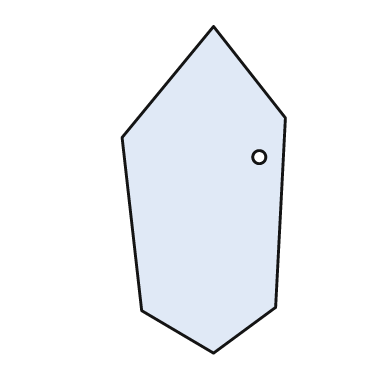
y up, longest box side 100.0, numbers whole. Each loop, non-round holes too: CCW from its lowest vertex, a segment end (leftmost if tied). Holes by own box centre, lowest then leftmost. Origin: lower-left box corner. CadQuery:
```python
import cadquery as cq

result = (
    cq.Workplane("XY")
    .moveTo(28.0, 0.0)
    .lineTo(47.0, 14.0)
    .lineTo(50.0, 72.0)
    .lineTo(28.0, 100.0)
    .lineTo(0.0, 66.0)
    .lineTo(6.0, 13.0)
    .close()
    .moveTo(42.0, 60.0)
    .circle(2.0)
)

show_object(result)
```